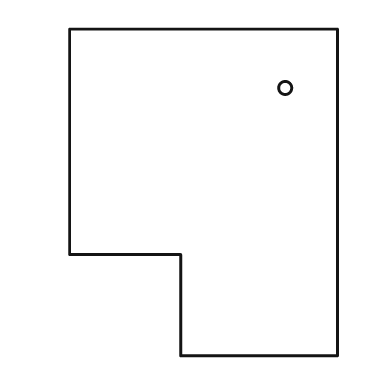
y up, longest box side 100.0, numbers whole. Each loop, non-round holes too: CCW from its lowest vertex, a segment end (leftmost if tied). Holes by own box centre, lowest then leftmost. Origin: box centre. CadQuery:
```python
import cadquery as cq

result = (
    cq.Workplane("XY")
    .moveTo(-7.0, -50.0)
    .lineTo(41.0, -50.0)
    .lineTo(41.0, 50.0)
    .lineTo(-41.0, 50.0)
    .lineTo(-41.0, -19.0)
    .lineTo(-7.0, -19.0)
    .close()
    .moveTo(25.0, 32.0)
    .circle(2.0)
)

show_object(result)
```